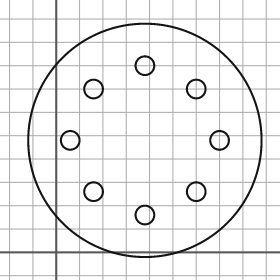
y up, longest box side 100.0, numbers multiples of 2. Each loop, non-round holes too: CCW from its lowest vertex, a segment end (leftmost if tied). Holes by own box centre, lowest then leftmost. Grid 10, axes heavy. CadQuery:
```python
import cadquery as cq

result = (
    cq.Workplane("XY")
    .moveTo(38.0, 48.0)
    .circle(50.0)
    .moveTo(38.0, 16.0)
    .circle(4.0)
    .moveTo(16.0, 26.0)
    .circle(4.0)
    .moveTo(60.0, 26.0)
    .circle(4.0)
    .moveTo(6.0, 48.0)
    .circle(4.0)
    .moveTo(70.0, 48.0)
    .circle(4.0)
    .moveTo(16.0, 70.0)
    .circle(4.0)
    .moveTo(60.0, 70.0)
    .circle(4.0)
    .moveTo(38.0, 80.0)
    .circle(4.0)
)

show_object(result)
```